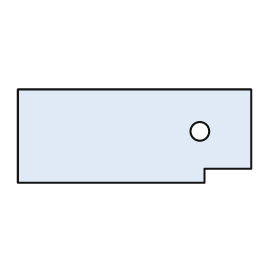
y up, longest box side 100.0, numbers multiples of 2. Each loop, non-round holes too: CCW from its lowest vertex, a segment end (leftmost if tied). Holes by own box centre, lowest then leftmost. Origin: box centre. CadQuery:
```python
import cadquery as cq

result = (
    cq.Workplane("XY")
    .moveTo(-50.0, -20.0)
    .lineTo(30.0, -20.0)
    .lineTo(30.0, -14.0)
    .lineTo(50.0, -14.0)
    .lineTo(50.0, 20.0)
    .lineTo(-50.0, 20.0)
    .close()
    .moveTo(28.0, 2.0)
    .circle(4.0)
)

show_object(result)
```